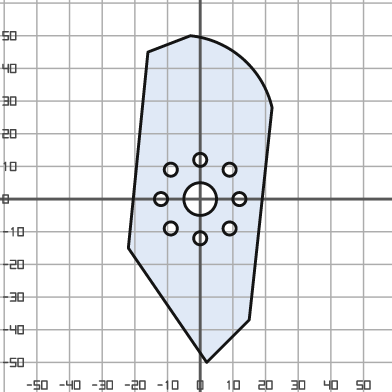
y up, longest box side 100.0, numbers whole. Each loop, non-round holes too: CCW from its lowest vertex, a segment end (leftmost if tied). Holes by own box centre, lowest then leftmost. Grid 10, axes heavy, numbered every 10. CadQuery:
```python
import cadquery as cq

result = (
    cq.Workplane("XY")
    .moveTo(2.0, -50.0)
    .lineTo(15.0, -37.0)
    .lineTo(22.0, 28.0)
    .threePointArc((13.0, 43.0), (-3.0, 50.0))
    .lineTo(-16.0, 45.0)
    .lineTo(-22.0, -15.0)
    .close()
    .moveTo(0.0, -12.0)
    .circle(2.0)
    .moveTo(-9.0, -9.0)
    .circle(2.0)
    .moveTo(9.0, -9.0)
    .circle(2.0)
    .moveTo(-12.0, 0.0)
    .circle(2.0)
    .moveTo(0.0, 0.0)
    .circle(5.0)
    .moveTo(12.0, 0.0)
    .circle(2.0)
    .moveTo(-9.0, 9.0)
    .circle(2.0)
    .moveTo(9.0, 9.0)
    .circle(2.0)
    .moveTo(0.0, 12.0)
    .circle(2.0)
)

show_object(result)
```